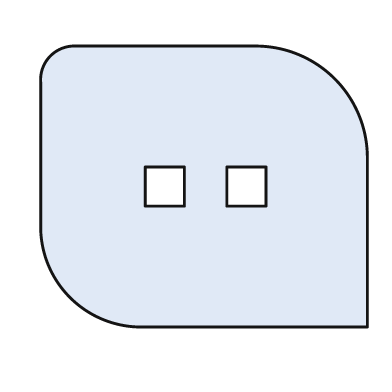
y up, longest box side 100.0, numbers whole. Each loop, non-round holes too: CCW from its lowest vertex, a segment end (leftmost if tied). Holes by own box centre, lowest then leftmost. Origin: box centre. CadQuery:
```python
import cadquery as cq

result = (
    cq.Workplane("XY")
    .moveTo(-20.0, -43.0)
    .lineTo(50.0, -43.0)
    .lineTo(50.0, 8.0)
    .threePointArc((40.0, 33.0), (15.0, 43.0))
    .lineTo(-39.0, 43.0)
    .threePointArc((-47.0, 40.0), (-50.0, 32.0))
    .lineTo(-50.0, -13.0)
    .threePointArc((-41.0, -34.0), (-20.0, -43.0))
    .close()
    .moveTo(-18.0, -6.0)
    .lineTo(-6.0, -6.0)
    .lineTo(-6.0, 6.0)
    .lineTo(-18.0, 6.0)
    .close()
    .moveTo(7.0, -6.0)
    .lineTo(19.0, -6.0)
    .lineTo(19.0, 6.0)
    .lineTo(7.0, 6.0)
    .close()
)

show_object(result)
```